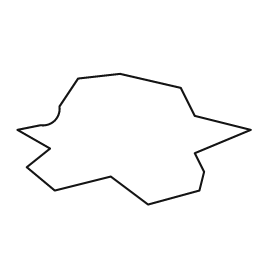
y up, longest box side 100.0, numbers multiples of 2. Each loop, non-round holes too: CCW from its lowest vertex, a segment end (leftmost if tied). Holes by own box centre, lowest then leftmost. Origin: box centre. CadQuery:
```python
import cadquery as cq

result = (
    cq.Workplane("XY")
    .moveTo(6.0, -28.0)
    .lineTo(28.0, -22.0)
    .lineTo(30.0, -14.0)
    .lineTo(26.0, -6.0)
    .lineTo(50.0, 4.0)
    .lineTo(26.0, 10.0)
    .lineTo(20.0, 22.0)
    .lineTo(-6.0, 28.0)
    .lineTo(-24.0, 26.0)
    .lineTo(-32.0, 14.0)
    .threePointArc((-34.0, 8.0), (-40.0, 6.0))
    .lineTo(-50.0, 4.0)
    .lineTo(-36.0, -4.0)
    .lineTo(-46.0, -12.0)
    .lineTo(-34.0, -22.0)
    .lineTo(-10.0, -16.0)
    .close()
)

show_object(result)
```